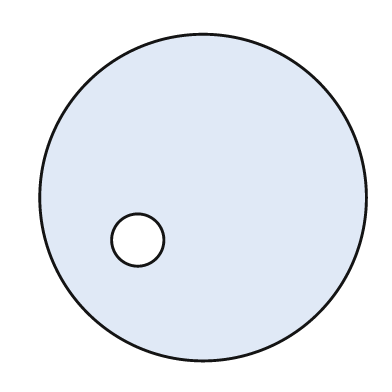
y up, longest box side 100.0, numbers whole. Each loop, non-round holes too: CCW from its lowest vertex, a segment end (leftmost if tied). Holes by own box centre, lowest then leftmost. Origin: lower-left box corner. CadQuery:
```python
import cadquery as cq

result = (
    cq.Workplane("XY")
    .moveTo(50.0, 50.0)
    .circle(50.0)
    .moveTo(30.0, 37.0)
    .circle(8.0)
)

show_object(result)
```